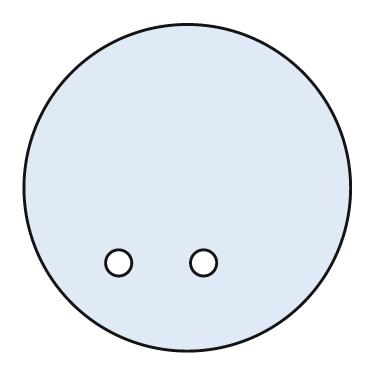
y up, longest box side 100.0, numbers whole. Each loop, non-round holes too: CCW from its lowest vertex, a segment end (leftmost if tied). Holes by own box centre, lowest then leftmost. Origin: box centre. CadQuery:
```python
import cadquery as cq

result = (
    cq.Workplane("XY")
    .moveTo(0.0, 0.0)
    .circle(50.0)
    .moveTo(-21.0, -23.0)
    .circle(4.0)
    .moveTo(5.0, -23.0)
    .circle(4.0)
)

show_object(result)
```